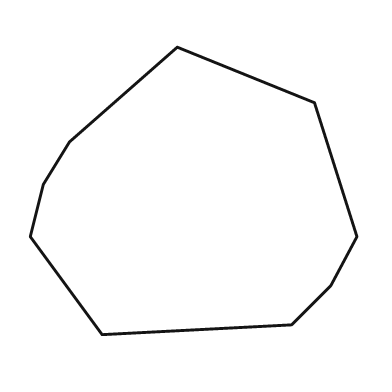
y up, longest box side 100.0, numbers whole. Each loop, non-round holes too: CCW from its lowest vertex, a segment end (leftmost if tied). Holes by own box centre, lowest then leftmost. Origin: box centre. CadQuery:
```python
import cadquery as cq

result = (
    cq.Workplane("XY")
    .moveTo(-28.0, -44.0)
    .lineTo(30.0, -41.0)
    .lineTo(42.0, -29.0)
    .lineTo(50.0, -14.0)
    .lineTo(37.0, 27.0)
    .lineTo(-5.0, 44.0)
    .lineTo(-38.0, 15.0)
    .lineTo(-46.0, 2.0)
    .lineTo(-50.0, -14.0)
    .close()
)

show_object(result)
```